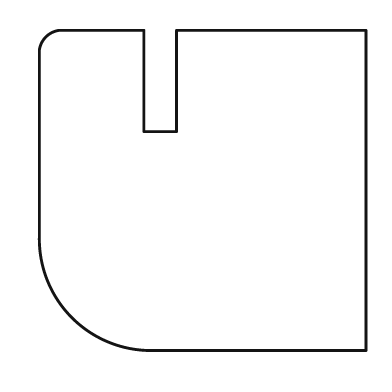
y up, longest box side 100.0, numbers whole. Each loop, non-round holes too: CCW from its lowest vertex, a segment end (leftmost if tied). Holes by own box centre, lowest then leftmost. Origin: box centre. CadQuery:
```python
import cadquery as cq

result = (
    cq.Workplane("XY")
    .moveTo(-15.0, -49.0)
    .lineTo(50.0, -49.0)
    .lineTo(50.0, 49.0)
    .lineTo(-8.0, 49.0)
    .lineTo(-8.0, 18.0)
    .lineTo(-18.0, 18.0)
    .lineTo(-18.0, 49.0)
    .lineTo(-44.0, 49.0)
    .threePointArc((-48.0, 47.0), (-50.0, 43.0))
    .lineTo(-50.0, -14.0)
    .threePointArc((-40.0, -39.0), (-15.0, -49.0))
    .close()
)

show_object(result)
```